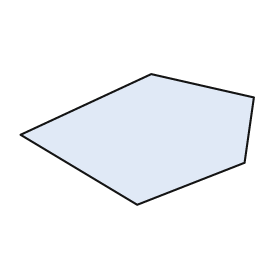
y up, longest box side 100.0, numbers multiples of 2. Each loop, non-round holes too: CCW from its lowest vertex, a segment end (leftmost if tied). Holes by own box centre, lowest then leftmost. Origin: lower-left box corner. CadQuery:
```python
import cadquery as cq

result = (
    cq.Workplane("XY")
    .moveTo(50.0, 0.0)
    .lineTo(96.0, 18.0)
    .lineTo(100.0, 46.0)
    .lineTo(56.0, 56.0)
    .lineTo(0.0, 30.0)
    .close()
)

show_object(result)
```